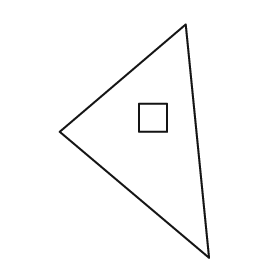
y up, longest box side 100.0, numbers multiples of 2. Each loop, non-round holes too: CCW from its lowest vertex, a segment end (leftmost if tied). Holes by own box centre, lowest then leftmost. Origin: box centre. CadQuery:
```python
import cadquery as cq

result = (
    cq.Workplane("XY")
    .moveTo(32.0, -50.0)
    .lineTo(22.0, 50.0)
    .lineTo(-32.0, 4.0)
    .close()
    .moveTo(2.0, 4.0)
    .lineTo(14.0, 4.0)
    .lineTo(14.0, 16.0)
    .lineTo(2.0, 16.0)
    .close()
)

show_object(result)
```